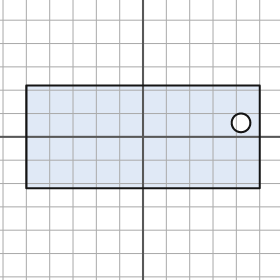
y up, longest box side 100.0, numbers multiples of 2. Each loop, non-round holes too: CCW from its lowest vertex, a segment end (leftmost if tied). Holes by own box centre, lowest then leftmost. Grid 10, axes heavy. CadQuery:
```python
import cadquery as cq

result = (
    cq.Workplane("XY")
    .moveTo(-50.0, -22.0)
    .lineTo(50.0, -22.0)
    .lineTo(50.0, 22.0)
    .lineTo(-50.0, 22.0)
    .close()
    .moveTo(42.0, 6.0)
    .circle(4.0)
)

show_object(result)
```